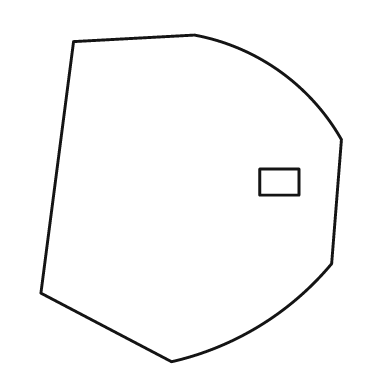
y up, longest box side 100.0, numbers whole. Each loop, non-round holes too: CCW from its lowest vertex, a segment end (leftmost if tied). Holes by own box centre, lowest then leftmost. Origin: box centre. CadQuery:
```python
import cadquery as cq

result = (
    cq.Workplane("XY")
    .moveTo(-6.0, -50.0)
    .threePointArc((21.0, -39.0), (43.0, -20.0))
    .lineTo(46.0, 18.0)
    .threePointArc((27.0, 39.0), (1.0, 50.0))
    .lineTo(-36.0, 48.0)
    .lineTo(-46.0, -29.0)
    .close()
    .moveTo(21.0, 1.0)
    .lineTo(33.0, 1.0)
    .lineTo(33.0, 9.0)
    .lineTo(21.0, 9.0)
    .close()
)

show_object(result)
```